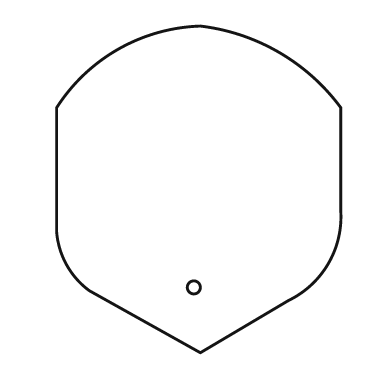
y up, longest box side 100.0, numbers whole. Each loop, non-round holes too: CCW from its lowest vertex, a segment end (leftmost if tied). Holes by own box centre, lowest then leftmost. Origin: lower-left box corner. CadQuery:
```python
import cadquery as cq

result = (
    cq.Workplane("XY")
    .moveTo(44.0, 0.0)
    .lineTo(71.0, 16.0)
    .threePointArc((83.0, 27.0), (87.0, 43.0))
    .lineTo(87.0, 75.0)
    .threePointArc((68.0, 92.0), (44.0, 100.0))
    .threePointArc((19.0, 93.0), (0.0, 75.0))
    .lineTo(0.0, 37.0)
    .threePointArc((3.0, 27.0), (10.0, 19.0))
    .close()
    .moveTo(42.0, 20.0)
    .circle(2.0)
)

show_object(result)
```